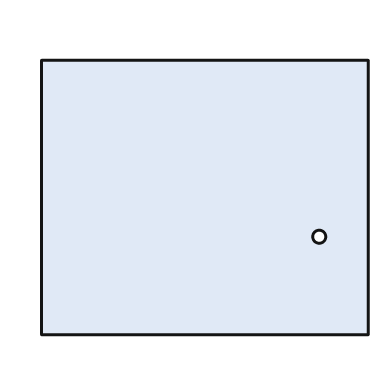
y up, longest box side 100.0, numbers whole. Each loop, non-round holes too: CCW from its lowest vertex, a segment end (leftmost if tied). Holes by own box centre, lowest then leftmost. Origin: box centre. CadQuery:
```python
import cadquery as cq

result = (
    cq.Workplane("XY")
    .moveTo(-50.0, -42.0)
    .lineTo(50.0, -42.0)
    .lineTo(50.0, 42.0)
    .lineTo(-50.0, 42.0)
    .close()
    .moveTo(35.0, -12.0)
    .circle(2.0)
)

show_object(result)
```